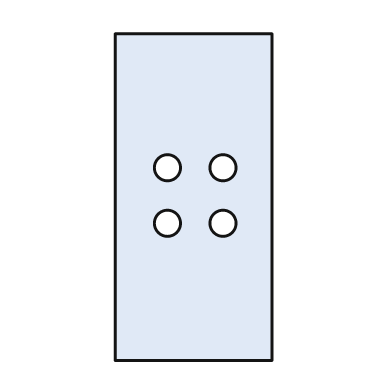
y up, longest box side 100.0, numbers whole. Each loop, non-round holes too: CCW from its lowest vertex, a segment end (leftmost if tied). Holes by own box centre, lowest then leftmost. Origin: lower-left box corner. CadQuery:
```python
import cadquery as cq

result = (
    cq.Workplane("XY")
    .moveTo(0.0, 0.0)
    .lineTo(48.0, 0.0)
    .lineTo(48.0, 100.0)
    .lineTo(0.0, 100.0)
    .close()
    .moveTo(16.0, 42.0)
    .circle(4.0)
    .moveTo(33.0, 42.0)
    .circle(4.0)
    .moveTo(16.0, 59.0)
    .circle(4.0)
    .moveTo(33.0, 59.0)
    .circle(4.0)
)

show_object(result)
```